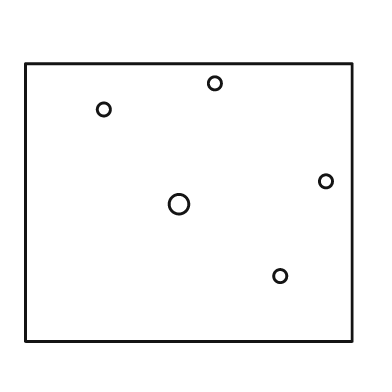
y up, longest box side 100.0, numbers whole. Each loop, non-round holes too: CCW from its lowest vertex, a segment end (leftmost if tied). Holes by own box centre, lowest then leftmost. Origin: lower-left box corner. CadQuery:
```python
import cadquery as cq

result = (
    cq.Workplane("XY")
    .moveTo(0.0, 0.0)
    .lineTo(100.0, 0.0)
    .lineTo(100.0, 85.0)
    .lineTo(0.0, 85.0)
    .close()
    .moveTo(78.0, 20.0)
    .circle(2.0)
    .moveTo(47.0, 42.0)
    .circle(3.0)
    .moveTo(92.0, 49.0)
    .circle(2.0)
    .moveTo(24.0, 71.0)
    .circle(2.0)
    .moveTo(58.0, 79.0)
    .circle(2.0)
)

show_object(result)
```